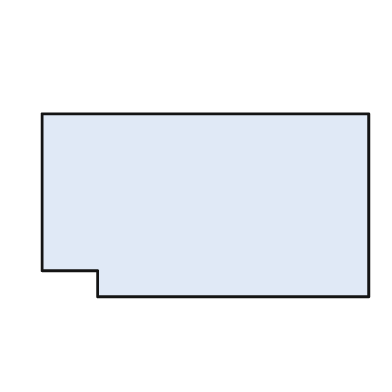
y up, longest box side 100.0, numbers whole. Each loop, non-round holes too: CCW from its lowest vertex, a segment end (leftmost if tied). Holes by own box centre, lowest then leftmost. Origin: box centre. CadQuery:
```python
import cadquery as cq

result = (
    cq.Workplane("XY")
    .moveTo(-33.0, -28.0)
    .lineTo(50.0, -28.0)
    .lineTo(50.0, 28.0)
    .lineTo(-50.0, 28.0)
    .lineTo(-50.0, -20.0)
    .lineTo(-33.0, -20.0)
    .close()
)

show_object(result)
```